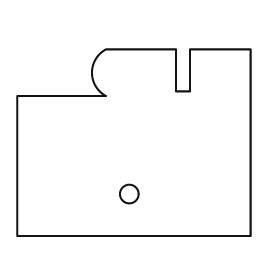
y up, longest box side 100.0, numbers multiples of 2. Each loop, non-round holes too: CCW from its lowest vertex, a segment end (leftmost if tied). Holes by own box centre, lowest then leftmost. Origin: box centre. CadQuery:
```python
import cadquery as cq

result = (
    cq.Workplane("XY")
    .moveTo(-50.0, -40.0)
    .lineTo(50.0, -40.0)
    .lineTo(50.0, 40.0)
    .lineTo(24.0, 40.0)
    .lineTo(24.0, 22.0)
    .lineTo(18.0, 22.0)
    .lineTo(18.0, 40.0)
    .lineTo(-12.0, 40.0)
    .threePointArc((-18.0, 30.0), (-12.0, 20.0))
    .lineTo(-50.0, 20.0)
    .close()
    .moveTo(-2.0, -22.0)
    .circle(4.0)
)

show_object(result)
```